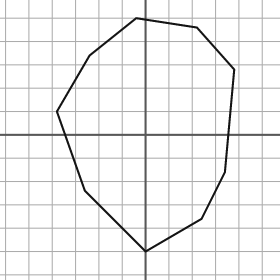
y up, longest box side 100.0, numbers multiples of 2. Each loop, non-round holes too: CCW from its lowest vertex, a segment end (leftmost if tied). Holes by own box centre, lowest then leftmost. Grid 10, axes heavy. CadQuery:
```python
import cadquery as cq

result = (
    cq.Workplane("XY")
    .moveTo(0.0, -50.0)
    .lineTo(24.0, -36.0)
    .lineTo(34.0, -16.0)
    .lineTo(38.0, 28.0)
    .lineTo(22.0, 46.0)
    .lineTo(-4.0, 50.0)
    .lineTo(-24.0, 34.0)
    .lineTo(-38.0, 10.0)
    .lineTo(-26.0, -24.0)
    .close()
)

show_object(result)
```